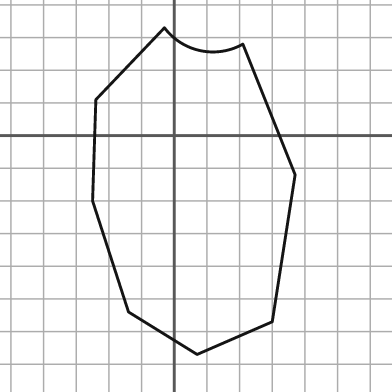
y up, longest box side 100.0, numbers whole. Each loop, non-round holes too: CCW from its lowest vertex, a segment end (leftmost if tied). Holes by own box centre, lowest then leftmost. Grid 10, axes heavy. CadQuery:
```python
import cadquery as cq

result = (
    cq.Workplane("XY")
    .moveTo(7.0, -67.0)
    .lineTo(30.0, -57.0)
    .lineTo(37.0, -12.0)
    .lineTo(21.0, 28.0)
    .threePointArc((8.0, 26.0), (-3.0, 33.0))
    .lineTo(-24.0, 11.0)
    .lineTo(-25.0, -20.0)
    .lineTo(-14.0, -54.0)
    .close()
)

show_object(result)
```